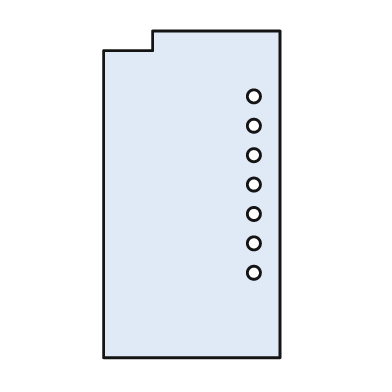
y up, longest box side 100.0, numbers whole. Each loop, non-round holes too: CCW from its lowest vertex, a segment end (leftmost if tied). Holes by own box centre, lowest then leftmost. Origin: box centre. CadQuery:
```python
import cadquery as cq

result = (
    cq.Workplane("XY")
    .moveTo(-27.0, -50.0)
    .lineTo(27.0, -50.0)
    .lineTo(27.0, 50.0)
    .lineTo(-12.0, 50.0)
    .lineTo(-12.0, 44.0)
    .lineTo(-27.0, 44.0)
    .close()
    .moveTo(19.0, -24.0)
    .circle(2.0)
    .moveTo(19.0, -15.0)
    .circle(2.0)
    .moveTo(19.0, -6.0)
    .circle(2.0)
    .moveTo(19.0, 3.0)
    .circle(2.0)
    .moveTo(19.0, 12.0)
    .circle(2.0)
    .moveTo(19.0, 21.0)
    .circle(2.0)
    .moveTo(19.0, 30.0)
    .circle(2.0)
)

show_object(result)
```